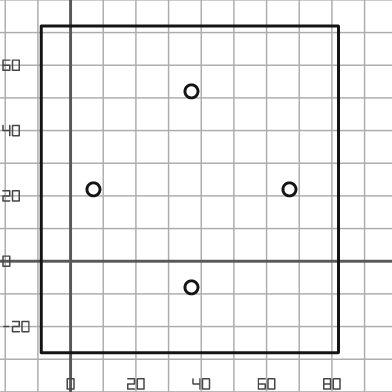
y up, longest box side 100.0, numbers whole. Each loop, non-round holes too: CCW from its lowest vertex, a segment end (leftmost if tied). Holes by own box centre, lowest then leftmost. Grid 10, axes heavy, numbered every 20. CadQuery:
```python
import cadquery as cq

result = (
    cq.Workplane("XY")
    .moveTo(-9.0, -28.0)
    .lineTo(82.0, -28.0)
    .lineTo(82.0, 72.0)
    .lineTo(-9.0, 72.0)
    .close()
    .moveTo(37.0, -8.0)
    .circle(2.0)
    .moveTo(7.0, 22.0)
    .circle(2.0)
    .moveTo(67.0, 22.0)
    .circle(2.0)
    .moveTo(37.0, 52.0)
    .circle(2.0)
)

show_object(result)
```